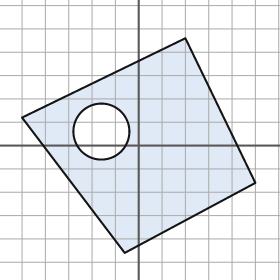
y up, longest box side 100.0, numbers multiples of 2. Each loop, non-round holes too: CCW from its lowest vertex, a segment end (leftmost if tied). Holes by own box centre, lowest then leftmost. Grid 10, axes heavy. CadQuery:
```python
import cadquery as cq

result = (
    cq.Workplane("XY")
    .moveTo(-6.0, -46.0)
    .lineTo(50.0, -16.0)
    .lineTo(20.0, 46.0)
    .lineTo(-50.0, 12.0)
    .close()
    .moveTo(-16.0, 6.0)
    .circle(12.0)
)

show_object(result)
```